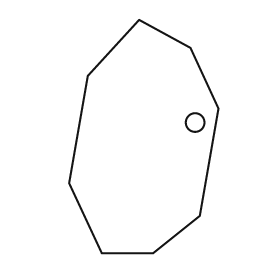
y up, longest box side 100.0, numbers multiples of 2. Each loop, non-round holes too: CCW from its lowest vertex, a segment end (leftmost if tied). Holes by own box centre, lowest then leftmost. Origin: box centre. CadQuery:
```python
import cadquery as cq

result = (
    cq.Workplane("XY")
    .moveTo(-18.0, -50.0)
    .lineTo(4.0, -50.0)
    .lineTo(24.0, -34.0)
    .lineTo(32.0, 12.0)
    .lineTo(20.0, 38.0)
    .lineTo(-2.0, 50.0)
    .lineTo(-24.0, 26.0)
    .lineTo(-32.0, -20.0)
    .close()
    .moveTo(22.0, 6.0)
    .circle(4.0)
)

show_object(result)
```